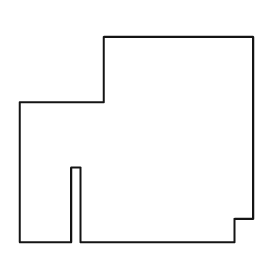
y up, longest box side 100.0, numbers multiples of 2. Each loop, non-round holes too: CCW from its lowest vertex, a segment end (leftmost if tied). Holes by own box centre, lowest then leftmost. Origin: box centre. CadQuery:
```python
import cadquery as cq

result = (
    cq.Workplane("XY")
    .moveTo(-50.0, -44.0)
    .lineTo(-28.0, -44.0)
    .lineTo(-28.0, -12.0)
    .lineTo(-24.0, -12.0)
    .lineTo(-24.0, -44.0)
    .lineTo(42.0, -44.0)
    .lineTo(42.0, -34.0)
    .lineTo(50.0, -34.0)
    .lineTo(50.0, 44.0)
    .lineTo(-14.0, 44.0)
    .lineTo(-14.0, 16.0)
    .lineTo(-50.0, 16.0)
    .close()
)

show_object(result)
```